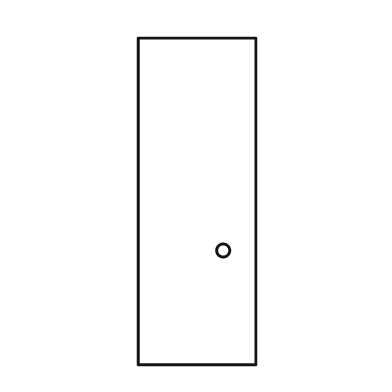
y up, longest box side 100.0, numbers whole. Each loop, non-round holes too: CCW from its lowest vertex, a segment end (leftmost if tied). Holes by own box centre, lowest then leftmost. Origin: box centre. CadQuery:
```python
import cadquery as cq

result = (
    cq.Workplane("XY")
    .moveTo(-18.0, -50.0)
    .lineTo(18.0, -50.0)
    .lineTo(18.0, 50.0)
    .lineTo(-18.0, 50.0)
    .close()
    .moveTo(8.0, -15.0)
    .circle(2.0)
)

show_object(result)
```